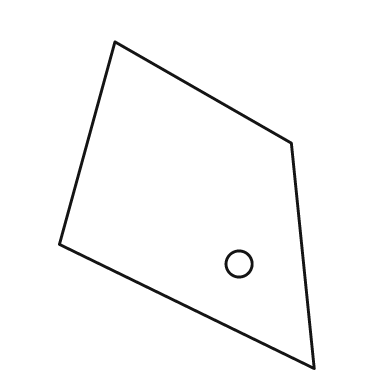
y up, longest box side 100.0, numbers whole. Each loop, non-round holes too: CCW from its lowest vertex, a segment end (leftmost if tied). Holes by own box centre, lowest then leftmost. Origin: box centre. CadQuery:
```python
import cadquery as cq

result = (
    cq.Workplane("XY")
    .moveTo(39.0, -50.0)
    .lineTo(32.0, 19.0)
    .lineTo(-22.0, 50.0)
    .lineTo(-39.0, -12.0)
    .close()
    .moveTo(16.0, -18.0)
    .circle(4.0)
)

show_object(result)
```